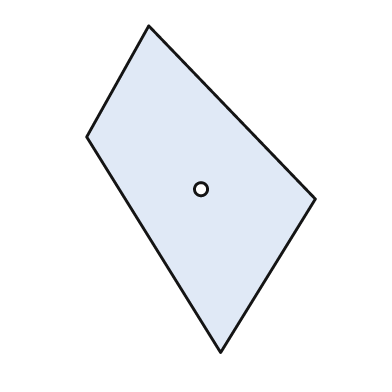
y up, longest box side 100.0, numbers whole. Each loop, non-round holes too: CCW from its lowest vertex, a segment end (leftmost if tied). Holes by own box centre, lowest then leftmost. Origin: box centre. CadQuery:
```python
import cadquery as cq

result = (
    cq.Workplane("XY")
    .moveTo(6.0, -50.0)
    .lineTo(35.0, -3.0)
    .lineTo(-16.0, 50.0)
    .lineTo(-35.0, 16.0)
    .close()
    .moveTo(0.0, 0.0)
    .circle(2.0)
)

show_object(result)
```